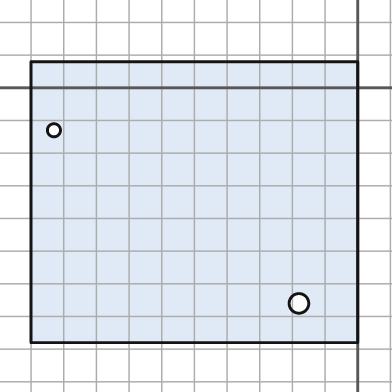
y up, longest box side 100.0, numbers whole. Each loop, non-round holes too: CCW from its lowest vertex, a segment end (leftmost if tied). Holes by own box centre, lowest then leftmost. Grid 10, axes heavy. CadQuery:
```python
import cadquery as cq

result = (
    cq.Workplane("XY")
    .moveTo(-100.0, -78.0)
    .lineTo(0.0, -78.0)
    .lineTo(0.0, 8.0)
    .lineTo(-100.0, 8.0)
    .close()
    .moveTo(-18.0, -66.0)
    .circle(3.0)
    .moveTo(-93.0, -13.0)
    .circle(2.0)
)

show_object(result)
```